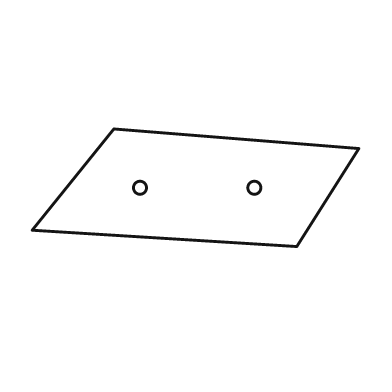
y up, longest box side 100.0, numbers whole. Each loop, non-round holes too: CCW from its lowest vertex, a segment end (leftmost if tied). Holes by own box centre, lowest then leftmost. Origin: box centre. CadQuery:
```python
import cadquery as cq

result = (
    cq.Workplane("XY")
    .moveTo(31.0, -18.0)
    .lineTo(50.0, 12.0)
    .lineTo(-25.0, 18.0)
    .lineTo(-50.0, -13.0)
    .close()
    .moveTo(-17.0, 0.0)
    .circle(2.0)
    .moveTo(18.0, 0.0)
    .circle(2.0)
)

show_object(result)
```